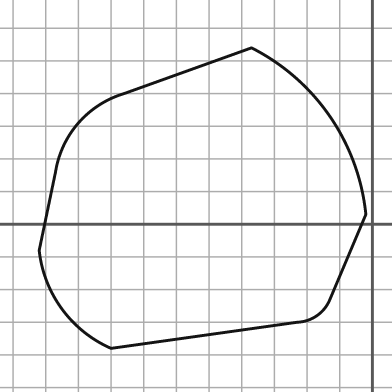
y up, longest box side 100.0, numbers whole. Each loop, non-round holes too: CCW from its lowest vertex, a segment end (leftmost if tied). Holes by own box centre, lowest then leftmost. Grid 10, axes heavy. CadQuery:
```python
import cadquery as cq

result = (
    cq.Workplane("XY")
    .moveTo(-80.0, -38.0)
    .lineTo(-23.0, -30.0)
    .threePointArc((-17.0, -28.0), (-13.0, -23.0))
    .lineTo(-2.0, 3.0)
    .threePointArc((-13.0, 33.0), (-37.0, 54.0))
    .lineTo(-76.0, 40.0)
    .threePointArc((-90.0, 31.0), (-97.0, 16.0))
    .lineTo(-102.0, -8.0)
    .threePointArc((-95.0, -26.0), (-80.0, -38.0))
    .close()
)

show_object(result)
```